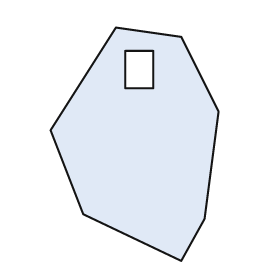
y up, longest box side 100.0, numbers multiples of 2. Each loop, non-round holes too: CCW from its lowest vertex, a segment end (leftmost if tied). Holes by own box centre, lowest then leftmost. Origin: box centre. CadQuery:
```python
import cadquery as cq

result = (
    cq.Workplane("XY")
    .moveTo(20.0, -50.0)
    .lineTo(30.0, -32.0)
    .lineTo(36.0, 14.0)
    .lineTo(20.0, 46.0)
    .lineTo(-8.0, 50.0)
    .lineTo(-36.0, 6.0)
    .lineTo(-22.0, -30.0)
    .close()
    .moveTo(-4.0, 24.0)
    .lineTo(8.0, 24.0)
    .lineTo(8.0, 40.0)
    .lineTo(-4.0, 40.0)
    .close()
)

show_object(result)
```